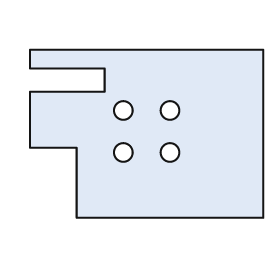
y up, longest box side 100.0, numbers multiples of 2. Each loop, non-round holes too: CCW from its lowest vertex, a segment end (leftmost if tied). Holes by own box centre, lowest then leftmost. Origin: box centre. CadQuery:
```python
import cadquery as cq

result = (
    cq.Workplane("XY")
    .moveTo(-30.0, -36.0)
    .lineTo(50.0, -36.0)
    .lineTo(50.0, 36.0)
    .lineTo(-50.0, 36.0)
    .lineTo(-50.0, 28.0)
    .lineTo(-18.0, 28.0)
    .lineTo(-18.0, 18.0)
    .lineTo(-50.0, 18.0)
    .lineTo(-50.0, -6.0)
    .lineTo(-30.0, -6.0)
    .close()
    .moveTo(-10.0, -8.0)
    .circle(4.0)
    .moveTo(10.0, -8.0)
    .circle(4.0)
    .moveTo(-10.0, 10.0)
    .circle(4.0)
    .moveTo(10.0, 10.0)
    .circle(4.0)
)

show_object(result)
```